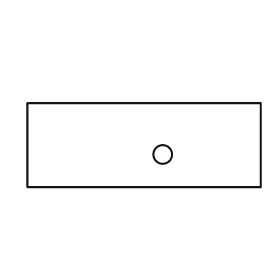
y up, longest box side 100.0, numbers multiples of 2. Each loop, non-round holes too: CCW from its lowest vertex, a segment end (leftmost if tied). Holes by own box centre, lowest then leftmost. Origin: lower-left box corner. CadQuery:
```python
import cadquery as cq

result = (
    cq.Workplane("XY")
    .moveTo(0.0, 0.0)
    .lineTo(100.0, 0.0)
    .lineTo(100.0, 36.0)
    .lineTo(0.0, 36.0)
    .close()
    .moveTo(58.0, 14.0)
    .circle(4.0)
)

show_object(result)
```